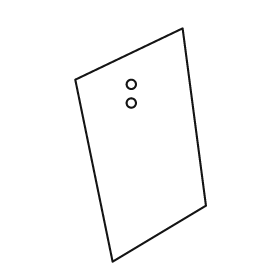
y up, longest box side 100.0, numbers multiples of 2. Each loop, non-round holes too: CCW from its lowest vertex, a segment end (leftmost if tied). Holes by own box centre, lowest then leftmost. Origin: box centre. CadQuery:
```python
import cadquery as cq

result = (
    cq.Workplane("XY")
    .moveTo(-12.0, -50.0)
    .lineTo(28.0, -26.0)
    .lineTo(18.0, 50.0)
    .lineTo(-28.0, 28.0)
    .close()
    .moveTo(-4.0, 18.0)
    .circle(2.0)
    .moveTo(-4.0, 26.0)
    .circle(2.0)
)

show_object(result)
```